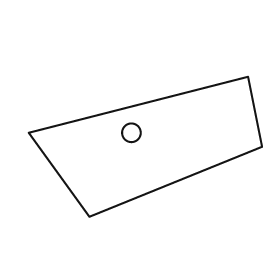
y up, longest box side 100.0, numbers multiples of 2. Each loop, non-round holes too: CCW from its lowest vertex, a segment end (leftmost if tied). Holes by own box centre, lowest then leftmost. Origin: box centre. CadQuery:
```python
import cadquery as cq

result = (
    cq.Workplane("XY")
    .moveTo(-24.0, -30.0)
    .lineTo(50.0, 0.0)
    .lineTo(44.0, 30.0)
    .lineTo(-50.0, 6.0)
    .close()
    .moveTo(-6.0, 6.0)
    .circle(4.0)
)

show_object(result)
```